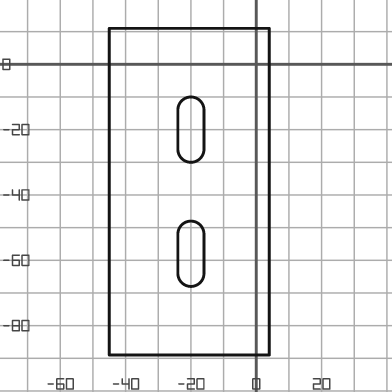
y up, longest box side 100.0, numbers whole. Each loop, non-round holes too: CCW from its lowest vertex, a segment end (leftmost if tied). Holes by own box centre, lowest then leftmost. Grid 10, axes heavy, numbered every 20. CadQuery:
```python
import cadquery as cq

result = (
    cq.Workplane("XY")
    .moveTo(-45.0, -89.0)
    .lineTo(4.0, -89.0)
    .lineTo(4.0, 11.0)
    .lineTo(-45.0, 11.0)
    .close()
    .moveTo(-24.0, -64.0)
    .threePointArc((-20.0, -68.0), (-16.0, -64.0))
    .lineTo(-16.0, -52.0)
    .threePointArc((-20.0, -48.0), (-24.0, -52.0))
    .close()
    .moveTo(-24.0, -26.0)
    .threePointArc((-20.0, -30.0), (-16.0, -26.0))
    .lineTo(-16.0, -14.0)
    .threePointArc((-20.0, -10.0), (-24.0, -14.0))
    .close()
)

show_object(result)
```